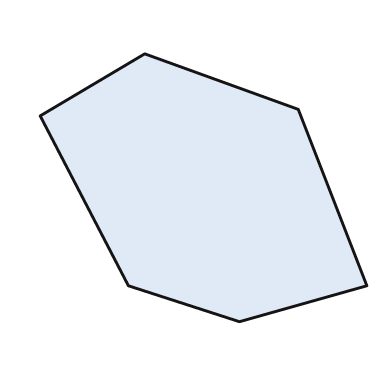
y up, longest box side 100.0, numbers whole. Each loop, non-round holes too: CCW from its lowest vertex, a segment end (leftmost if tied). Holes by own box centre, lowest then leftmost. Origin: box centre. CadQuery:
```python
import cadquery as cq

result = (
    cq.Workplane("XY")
    .moveTo(11.0, -41.0)
    .lineTo(50.0, -30.0)
    .lineTo(29.0, 24.0)
    .lineTo(-18.0, 41.0)
    .lineTo(-50.0, 22.0)
    .lineTo(-23.0, -30.0)
    .close()
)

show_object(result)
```